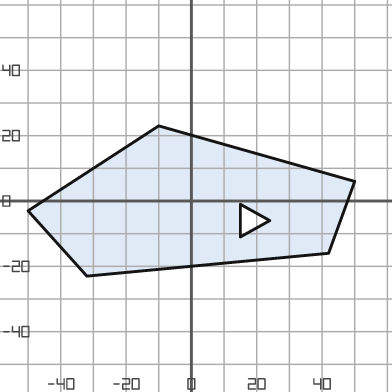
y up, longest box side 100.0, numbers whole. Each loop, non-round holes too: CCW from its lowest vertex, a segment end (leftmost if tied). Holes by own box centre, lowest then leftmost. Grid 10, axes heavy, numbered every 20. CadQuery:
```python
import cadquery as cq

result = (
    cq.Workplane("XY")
    .moveTo(-32.0, -23.0)
    .lineTo(42.0, -16.0)
    .lineTo(50.0, 6.0)
    .lineTo(-10.0, 23.0)
    .lineTo(-50.0, -3.0)
    .close()
    .moveTo(15.0, -11.0)
    .lineTo(24.0, -6.0)
    .lineTo(15.0, -1.0)
    .close()
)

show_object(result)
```